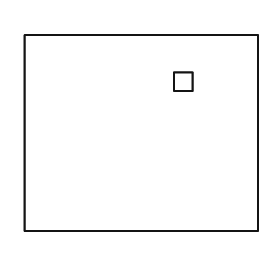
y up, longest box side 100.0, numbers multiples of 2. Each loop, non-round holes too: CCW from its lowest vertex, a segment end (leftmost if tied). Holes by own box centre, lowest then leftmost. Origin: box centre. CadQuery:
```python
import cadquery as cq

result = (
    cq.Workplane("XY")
    .moveTo(-50.0, -42.0)
    .lineTo(50.0, -42.0)
    .lineTo(50.0, 42.0)
    .lineTo(-50.0, 42.0)
    .close()
    .moveTo(14.0, 18.0)
    .lineTo(22.0, 18.0)
    .lineTo(22.0, 26.0)
    .lineTo(14.0, 26.0)
    .close()
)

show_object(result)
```